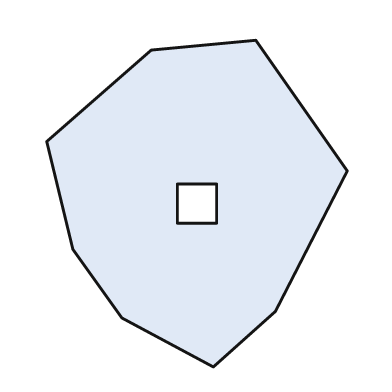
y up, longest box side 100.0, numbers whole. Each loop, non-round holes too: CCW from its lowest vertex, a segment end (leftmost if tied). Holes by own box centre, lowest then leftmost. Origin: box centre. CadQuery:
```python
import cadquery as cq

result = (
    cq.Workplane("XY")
    .moveTo(5.0, -50.0)
    .lineTo(24.0, -33.0)
    .lineTo(46.0, 10.0)
    .lineTo(18.0, 50.0)
    .lineTo(-14.0, 47.0)
    .lineTo(-46.0, 19.0)
    .lineTo(-38.0, -14.0)
    .lineTo(-23.0, -35.0)
    .close()
    .moveTo(-6.0, -6.0)
    .lineTo(6.0, -6.0)
    .lineTo(6.0, 6.0)
    .lineTo(-6.0, 6.0)
    .close()
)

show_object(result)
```